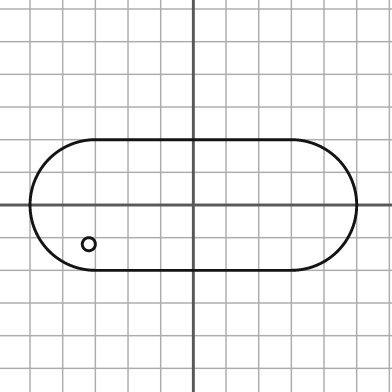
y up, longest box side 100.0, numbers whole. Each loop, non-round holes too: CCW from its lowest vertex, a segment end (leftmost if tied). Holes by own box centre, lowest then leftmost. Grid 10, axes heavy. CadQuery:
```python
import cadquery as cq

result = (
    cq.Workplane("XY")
    .moveTo(-30.0, -20.0)
    .lineTo(30.0, -20.0)
    .threePointArc((50.0, 0.0), (30.0, 20.0))
    .lineTo(-30.0, 20.0)
    .threePointArc((-50.0, 0.0), (-30.0, -20.0))
    .close()
    .moveTo(-32.0, -12.0)
    .circle(2.0)
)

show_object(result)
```